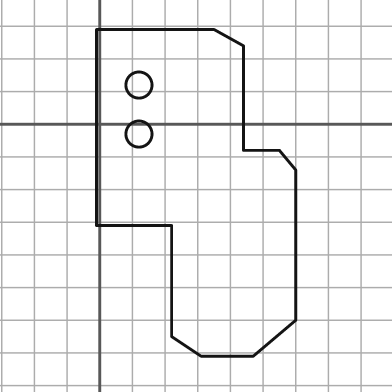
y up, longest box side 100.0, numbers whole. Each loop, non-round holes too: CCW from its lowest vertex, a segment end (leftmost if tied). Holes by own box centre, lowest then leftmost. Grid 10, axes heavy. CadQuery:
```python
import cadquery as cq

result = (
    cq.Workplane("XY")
    .moveTo(31.0, -71.0)
    .lineTo(47.0, -71.0)
    .lineTo(60.0, -60.0)
    .lineTo(60.0, -14.0)
    .lineTo(55.0, -8.0)
    .lineTo(44.0, -8.0)
    .lineTo(44.0, 24.0)
    .lineTo(35.0, 29.0)
    .lineTo(-1.0, 29.0)
    .lineTo(-1.0, -31.0)
    .lineTo(22.0, -31.0)
    .lineTo(22.0, -65.0)
    .close()
    .moveTo(12.0, -3.0)
    .circle(4.0)
    .moveTo(12.0, 12.0)
    .circle(4.0)
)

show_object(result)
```